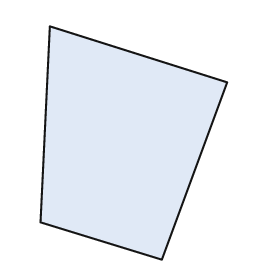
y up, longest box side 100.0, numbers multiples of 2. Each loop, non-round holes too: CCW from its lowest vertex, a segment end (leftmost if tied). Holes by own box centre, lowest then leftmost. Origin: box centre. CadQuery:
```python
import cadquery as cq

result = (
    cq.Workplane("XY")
    .moveTo(12.0, -50.0)
    .lineTo(40.0, 26.0)
    .lineTo(-36.0, 50.0)
    .lineTo(-40.0, -34.0)
    .close()
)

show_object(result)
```